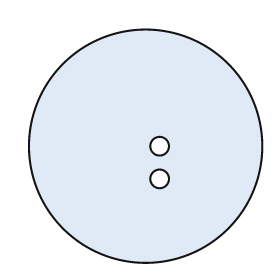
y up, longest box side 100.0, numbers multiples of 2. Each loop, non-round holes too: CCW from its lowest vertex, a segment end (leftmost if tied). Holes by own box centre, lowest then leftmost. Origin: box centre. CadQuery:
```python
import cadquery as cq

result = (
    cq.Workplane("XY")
    .moveTo(0.0, 0.0)
    .circle(50.0)
    .moveTo(6.0, -14.0)
    .circle(4.0)
    .moveTo(6.0, 0.0)
    .circle(4.0)
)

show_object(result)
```